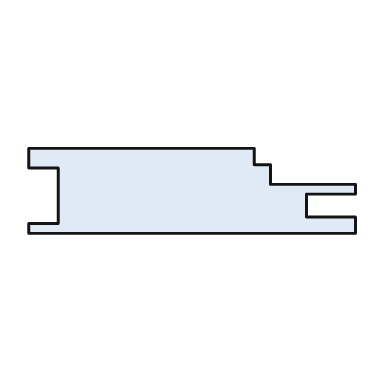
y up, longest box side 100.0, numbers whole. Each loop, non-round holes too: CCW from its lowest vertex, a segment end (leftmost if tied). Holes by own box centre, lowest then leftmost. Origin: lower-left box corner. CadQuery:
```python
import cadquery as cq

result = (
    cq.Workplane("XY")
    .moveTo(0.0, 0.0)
    .lineTo(100.0, 0.0)
    .lineTo(100.0, 5.0)
    .lineTo(85.0, 5.0)
    .lineTo(85.0, 12.0)
    .lineTo(100.0, 12.0)
    .lineTo(100.0, 15.0)
    .lineTo(74.0, 15.0)
    .lineTo(74.0, 21.0)
    .lineTo(69.0, 21.0)
    .lineTo(69.0, 26.0)
    .lineTo(0.0, 26.0)
    .lineTo(0.0, 20.0)
    .lineTo(9.0, 20.0)
    .lineTo(9.0, 3.0)
    .lineTo(0.0, 3.0)
    .close()
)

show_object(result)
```